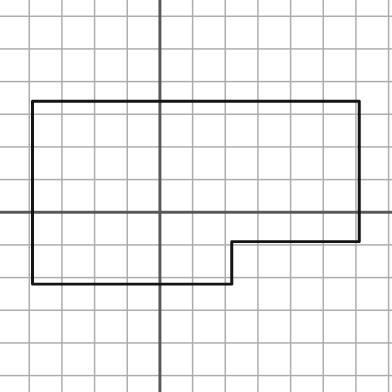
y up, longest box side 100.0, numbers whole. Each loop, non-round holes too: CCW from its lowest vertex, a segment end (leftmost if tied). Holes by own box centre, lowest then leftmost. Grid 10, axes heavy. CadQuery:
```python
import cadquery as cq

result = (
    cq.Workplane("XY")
    .moveTo(-39.0, -22.0)
    .lineTo(22.0, -22.0)
    .lineTo(22.0, -9.0)
    .lineTo(61.0, -9.0)
    .lineTo(61.0, 34.0)
    .lineTo(-39.0, 34.0)
    .close()
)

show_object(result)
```